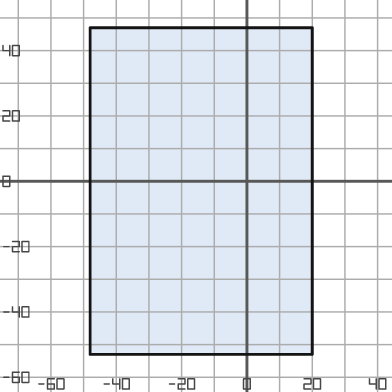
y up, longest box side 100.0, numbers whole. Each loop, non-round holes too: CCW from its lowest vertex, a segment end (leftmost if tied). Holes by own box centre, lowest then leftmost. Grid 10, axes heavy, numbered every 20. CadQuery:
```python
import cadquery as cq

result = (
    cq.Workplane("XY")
    .moveTo(-48.0, -53.0)
    .lineTo(20.0, -53.0)
    .lineTo(20.0, 47.0)
    .lineTo(-48.0, 47.0)
    .close()
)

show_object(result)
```